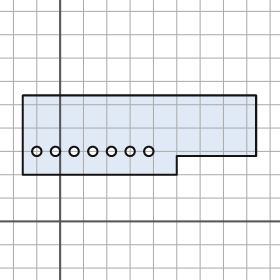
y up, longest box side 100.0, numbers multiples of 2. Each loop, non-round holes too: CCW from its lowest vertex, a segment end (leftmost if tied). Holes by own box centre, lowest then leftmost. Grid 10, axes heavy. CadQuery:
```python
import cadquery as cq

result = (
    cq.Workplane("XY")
    .moveTo(-16.0, 20.0)
    .lineTo(50.0, 20.0)
    .lineTo(50.0, 28.0)
    .lineTo(84.0, 28.0)
    .lineTo(84.0, 54.0)
    .lineTo(-16.0, 54.0)
    .close()
    .moveTo(-10.0, 30.0)
    .circle(2.0)
    .moveTo(-2.0, 30.0)
    .circle(2.0)
    .moveTo(6.0, 30.0)
    .circle(2.0)
    .moveTo(14.0, 30.0)
    .circle(2.0)
    .moveTo(22.0, 30.0)
    .circle(2.0)
    .moveTo(30.0, 30.0)
    .circle(2.0)
    .moveTo(38.0, 30.0)
    .circle(2.0)
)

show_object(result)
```